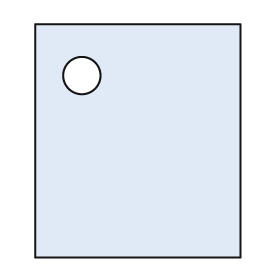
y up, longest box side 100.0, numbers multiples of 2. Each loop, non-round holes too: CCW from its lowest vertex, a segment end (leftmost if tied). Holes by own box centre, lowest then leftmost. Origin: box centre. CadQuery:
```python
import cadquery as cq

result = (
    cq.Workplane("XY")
    .moveTo(-44.0, -50.0)
    .lineTo(44.0, -50.0)
    .lineTo(44.0, 50.0)
    .lineTo(-44.0, 50.0)
    .close()
    .moveTo(-24.0, 28.0)
    .circle(8.0)
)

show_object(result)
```